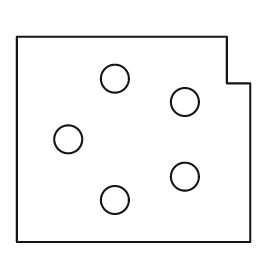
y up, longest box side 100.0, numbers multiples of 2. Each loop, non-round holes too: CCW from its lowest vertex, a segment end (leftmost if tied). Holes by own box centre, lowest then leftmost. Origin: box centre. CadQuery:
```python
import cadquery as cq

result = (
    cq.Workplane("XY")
    .moveTo(-50.0, -44.0)
    .lineTo(50.0, -44.0)
    .lineTo(50.0, 24.0)
    .lineTo(40.0, 24.0)
    .lineTo(40.0, 44.0)
    .lineTo(-50.0, 44.0)
    .close()
    .moveTo(-8.0, -26.0)
    .circle(6.0)
    .moveTo(22.0, -16.0)
    .circle(6.0)
    .moveTo(-28.0, 0.0)
    .circle(6.0)
    .moveTo(22.0, 16.0)
    .circle(6.0)
    .moveTo(-8.0, 26.0)
    .circle(6.0)
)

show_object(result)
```